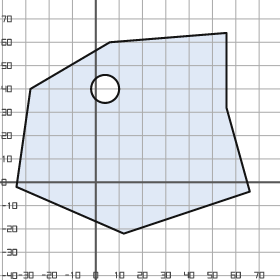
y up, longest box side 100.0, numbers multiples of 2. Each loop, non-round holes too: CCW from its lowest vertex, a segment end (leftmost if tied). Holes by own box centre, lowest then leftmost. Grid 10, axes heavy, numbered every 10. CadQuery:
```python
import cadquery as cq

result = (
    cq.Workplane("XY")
    .moveTo(12.0, -22.0)
    .lineTo(66.0, -4.0)
    .lineTo(56.0, 32.0)
    .lineTo(56.0, 64.0)
    .lineTo(6.0, 60.0)
    .lineTo(-28.0, 40.0)
    .lineTo(-34.0, -2.0)
    .close()
    .moveTo(4.0, 40.0)
    .circle(6.0)
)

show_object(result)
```